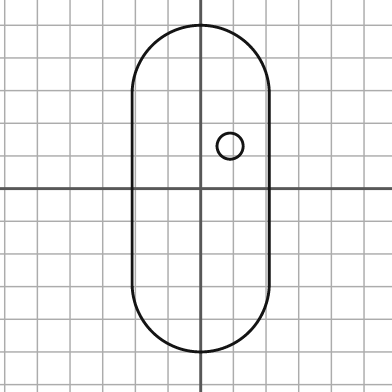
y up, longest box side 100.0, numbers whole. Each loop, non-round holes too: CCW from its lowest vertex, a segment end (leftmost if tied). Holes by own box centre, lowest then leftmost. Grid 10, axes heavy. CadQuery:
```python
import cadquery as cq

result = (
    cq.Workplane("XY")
    .moveTo(-21.0, -29.0)
    .threePointArc((0.0, -50.0), (21.0, -29.0))
    .lineTo(21.0, 29.0)
    .threePointArc((0.0, 50.0), (-21.0, 29.0))
    .close()
    .moveTo(9.0, 13.0)
    .circle(4.0)
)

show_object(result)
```